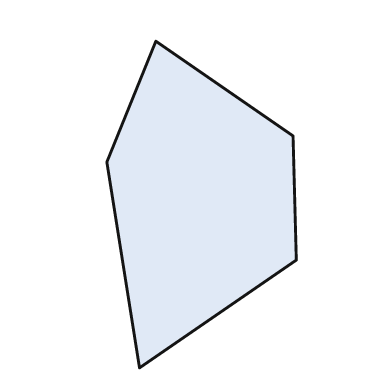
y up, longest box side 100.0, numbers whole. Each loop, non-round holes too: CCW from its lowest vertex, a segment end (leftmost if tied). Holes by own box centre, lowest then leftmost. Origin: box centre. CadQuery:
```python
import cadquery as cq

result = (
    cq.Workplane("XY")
    .moveTo(-19.0, -50.0)
    .lineTo(29.0, -17.0)
    .lineTo(28.0, 21.0)
    .lineTo(-14.0, 50.0)
    .lineTo(-29.0, 13.0)
    .close()
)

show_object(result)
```